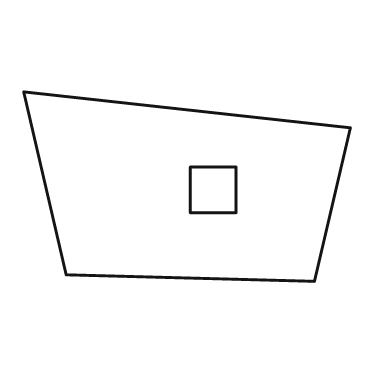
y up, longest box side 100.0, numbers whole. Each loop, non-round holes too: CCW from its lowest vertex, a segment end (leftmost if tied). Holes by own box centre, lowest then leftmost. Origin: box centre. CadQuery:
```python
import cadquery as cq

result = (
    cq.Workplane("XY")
    .moveTo(39.0, -29.0)
    .lineTo(50.0, 18.0)
    .lineTo(-50.0, 29.0)
    .lineTo(-37.0, -27.0)
    .close()
    .moveTo(1.0, -8.0)
    .lineTo(15.0, -8.0)
    .lineTo(15.0, 6.0)
    .lineTo(1.0, 6.0)
    .close()
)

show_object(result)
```